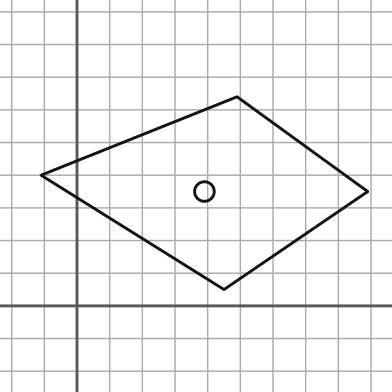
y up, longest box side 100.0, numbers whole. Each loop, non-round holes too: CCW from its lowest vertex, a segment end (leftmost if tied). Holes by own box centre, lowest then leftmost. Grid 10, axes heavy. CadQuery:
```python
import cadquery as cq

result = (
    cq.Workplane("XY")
    .moveTo(45.0, 5.0)
    .lineTo(89.0, 35.0)
    .lineTo(49.0, 64.0)
    .lineTo(-11.0, 40.0)
    .close()
    .moveTo(39.0, 35.0)
    .circle(3.0)
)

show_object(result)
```